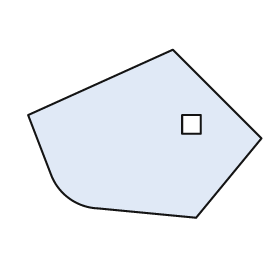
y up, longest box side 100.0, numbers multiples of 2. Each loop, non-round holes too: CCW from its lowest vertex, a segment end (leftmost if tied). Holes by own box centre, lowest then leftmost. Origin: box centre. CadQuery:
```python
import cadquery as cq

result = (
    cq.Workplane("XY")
    .moveTo(22.0, -36.0)
    .lineTo(50.0, -2.0)
    .lineTo(12.0, 36.0)
    .lineTo(-50.0, 8.0)
    .lineTo(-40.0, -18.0)
    .threePointArc((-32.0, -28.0), (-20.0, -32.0))
    .close()
    .moveTo(16.0, 0.0)
    .lineTo(24.0, 0.0)
    .lineTo(24.0, 8.0)
    .lineTo(16.0, 8.0)
    .close()
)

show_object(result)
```